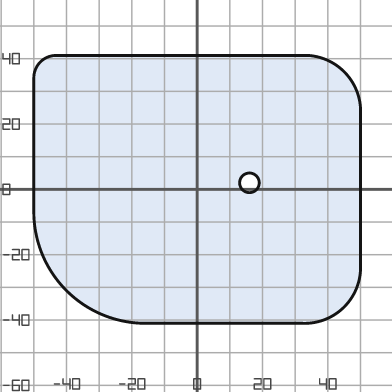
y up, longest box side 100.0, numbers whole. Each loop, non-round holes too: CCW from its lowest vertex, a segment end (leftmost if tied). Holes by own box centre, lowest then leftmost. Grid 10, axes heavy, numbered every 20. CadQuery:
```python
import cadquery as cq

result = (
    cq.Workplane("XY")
    .moveTo(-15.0, -41.0)
    .lineTo(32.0, -41.0)
    .threePointArc((45.0, -36.0), (50.0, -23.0))
    .lineTo(50.0, 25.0)
    .threePointArc((45.0, 36.0), (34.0, 41.0))
    .lineTo(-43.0, 41.0)
    .threePointArc((-48.0, 39.0), (-50.0, 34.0))
    .lineTo(-50.0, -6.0)
    .threePointArc((-40.0, -31.0), (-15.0, -41.0))
    .close()
    .moveTo(16.0, 2.0)
    .circle(3.0)
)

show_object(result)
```